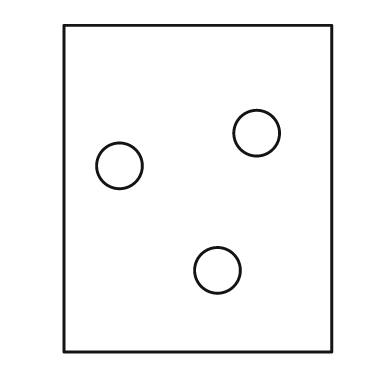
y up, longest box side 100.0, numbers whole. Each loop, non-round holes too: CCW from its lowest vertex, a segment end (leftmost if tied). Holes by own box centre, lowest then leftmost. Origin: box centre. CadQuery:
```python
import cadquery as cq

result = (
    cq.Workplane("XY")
    .moveTo(-41.0, -50.0)
    .lineTo(41.0, -50.0)
    .lineTo(41.0, 50.0)
    .lineTo(-41.0, 50.0)
    .close()
    .moveTo(6.0, -25.0)
    .circle(7.0)
    .moveTo(-24.0, 7.0)
    .circle(7.0)
    .moveTo(18.0, 17.0)
    .circle(7.0)
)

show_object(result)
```